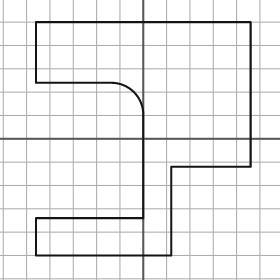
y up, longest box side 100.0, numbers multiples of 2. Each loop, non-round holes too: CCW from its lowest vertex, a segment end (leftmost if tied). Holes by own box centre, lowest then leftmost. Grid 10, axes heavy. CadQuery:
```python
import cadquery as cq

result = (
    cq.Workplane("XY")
    .moveTo(-46.0, -50.0)
    .lineTo(12.0, -50.0)
    .lineTo(12.0, -12.0)
    .lineTo(46.0, -12.0)
    .lineTo(46.0, 50.0)
    .lineTo(-46.0, 50.0)
    .lineTo(-46.0, 24.0)
    .lineTo(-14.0, 24.0)
    .threePointArc((-4.0, 20.0), (0.0, 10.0))
    .lineTo(0.0, -34.0)
    .lineTo(-46.0, -34.0)
    .close()
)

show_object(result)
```